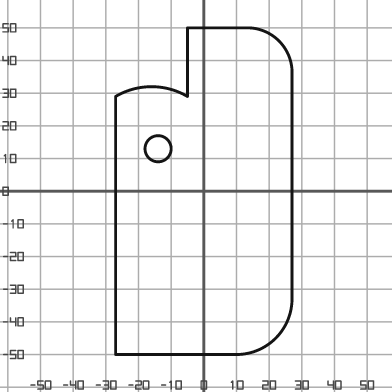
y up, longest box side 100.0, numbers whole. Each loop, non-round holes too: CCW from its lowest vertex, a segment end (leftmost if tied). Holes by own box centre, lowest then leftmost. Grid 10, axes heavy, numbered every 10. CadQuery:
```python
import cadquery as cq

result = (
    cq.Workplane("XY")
    .moveTo(-27.0, -50.0)
    .lineTo(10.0, -50.0)
    .threePointArc((22.0, -45.0), (27.0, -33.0))
    .lineTo(27.0, 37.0)
    .threePointArc((23.0, 46.0), (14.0, 50.0))
    .lineTo(-5.0, 50.0)
    .lineTo(-5.0, 29.0)
    .threePointArc((-16.0, 32.0), (-27.0, 29.0))
    .close()
    .moveTo(-14.0, 13.0)
    .circle(4.0)
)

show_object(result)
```